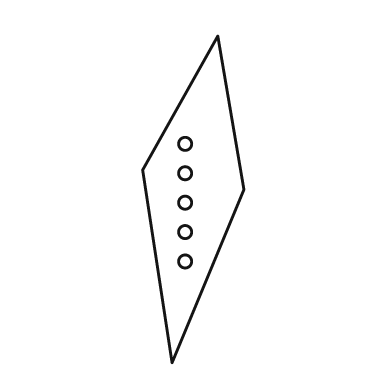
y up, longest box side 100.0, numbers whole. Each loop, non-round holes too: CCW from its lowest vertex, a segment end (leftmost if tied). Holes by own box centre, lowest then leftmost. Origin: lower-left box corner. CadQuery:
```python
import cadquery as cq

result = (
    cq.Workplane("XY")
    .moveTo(9.0, 0.0)
    .lineTo(31.0, 53.0)
    .lineTo(23.0, 100.0)
    .lineTo(0.0, 59.0)
    .close()
    .moveTo(13.0, 31.0)
    .circle(2.0)
    .moveTo(13.0, 40.0)
    .circle(2.0)
    .moveTo(13.0, 49.0)
    .circle(2.0)
    .moveTo(13.0, 58.0)
    .circle(2.0)
    .moveTo(13.0, 67.0)
    .circle(2.0)
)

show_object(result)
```